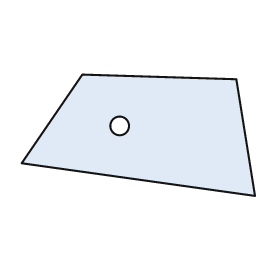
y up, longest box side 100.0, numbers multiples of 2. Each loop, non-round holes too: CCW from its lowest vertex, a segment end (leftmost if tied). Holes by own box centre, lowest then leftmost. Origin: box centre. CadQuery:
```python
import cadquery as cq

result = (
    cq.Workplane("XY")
    .moveTo(50.0, -26.0)
    .lineTo(42.0, 24.0)
    .lineTo(-24.0, 26.0)
    .lineTo(-50.0, -12.0)
    .close()
    .moveTo(-8.0, 4.0)
    .circle(4.0)
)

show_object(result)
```